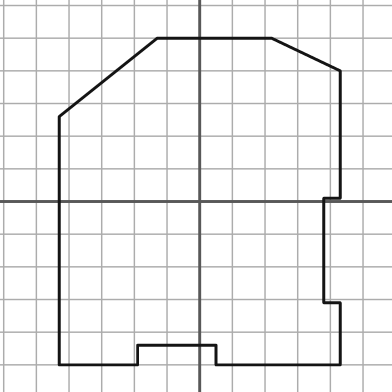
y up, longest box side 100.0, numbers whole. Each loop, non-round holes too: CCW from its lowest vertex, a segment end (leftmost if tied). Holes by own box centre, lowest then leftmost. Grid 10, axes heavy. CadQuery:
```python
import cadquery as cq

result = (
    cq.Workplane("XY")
    .moveTo(-43.0, -50.0)
    .lineTo(-19.0, -50.0)
    .lineTo(-19.0, -44.0)
    .lineTo(5.0, -44.0)
    .lineTo(5.0, -50.0)
    .lineTo(43.0, -50.0)
    .lineTo(43.0, -31.0)
    .lineTo(38.0, -31.0)
    .lineTo(38.0, 1.0)
    .lineTo(43.0, 1.0)
    .lineTo(43.0, 40.0)
    .lineTo(22.0, 50.0)
    .lineTo(-13.0, 50.0)
    .lineTo(-43.0, 26.0)
    .close()
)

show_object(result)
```